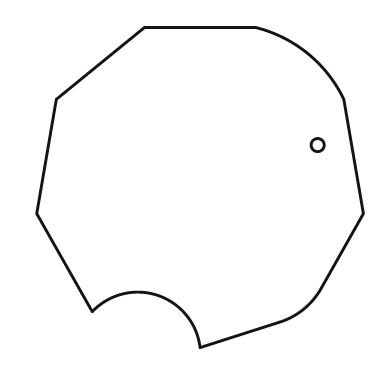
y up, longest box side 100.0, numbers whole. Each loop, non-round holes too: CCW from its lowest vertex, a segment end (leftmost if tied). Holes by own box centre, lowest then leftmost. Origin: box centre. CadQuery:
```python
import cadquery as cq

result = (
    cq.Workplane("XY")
    .moveTo(0.0, -49.0)
    .lineTo(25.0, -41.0)
    .threePointArc((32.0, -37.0), (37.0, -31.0))
    .lineTo(50.0, -8.0)
    .lineTo(44.0, 27.0)
    .threePointArc((33.0, 41.0), (17.0, 49.0))
    .lineTo(-17.0, 49.0)
    .lineTo(-44.0, 27.0)
    .lineTo(-50.0, -8.0)
    .lineTo(-33.0, -38.0)
    .threePointArc((-13.0, -33.0), (0.0, -49.0))
    .close()
    .moveTo(36.0, 13.0)
    .circle(2.0)
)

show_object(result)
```